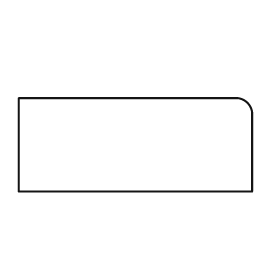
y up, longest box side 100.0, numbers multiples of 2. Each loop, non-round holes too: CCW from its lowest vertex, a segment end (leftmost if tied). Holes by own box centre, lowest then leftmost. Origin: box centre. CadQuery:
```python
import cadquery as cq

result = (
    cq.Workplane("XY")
    .moveTo(-50.0, -20.0)
    .lineTo(50.0, -20.0)
    .lineTo(50.0, 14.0)
    .threePointArc((48.0, 18.0), (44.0, 20.0))
    .lineTo(-50.0, 20.0)
    .close()
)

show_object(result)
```